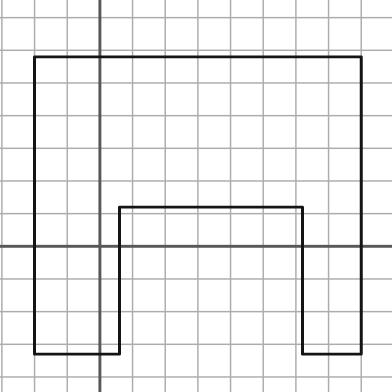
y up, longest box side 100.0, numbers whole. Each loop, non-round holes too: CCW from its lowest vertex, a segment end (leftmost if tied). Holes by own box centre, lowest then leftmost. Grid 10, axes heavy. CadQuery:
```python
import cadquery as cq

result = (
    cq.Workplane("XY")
    .moveTo(-20.0, -33.0)
    .lineTo(6.0, -33.0)
    .lineTo(6.0, 12.0)
    .lineTo(62.0, 12.0)
    .lineTo(62.0, -33.0)
    .lineTo(80.0, -33.0)
    .lineTo(80.0, 58.0)
    .lineTo(-20.0, 58.0)
    .close()
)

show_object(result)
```